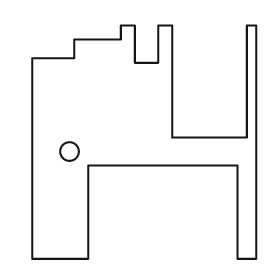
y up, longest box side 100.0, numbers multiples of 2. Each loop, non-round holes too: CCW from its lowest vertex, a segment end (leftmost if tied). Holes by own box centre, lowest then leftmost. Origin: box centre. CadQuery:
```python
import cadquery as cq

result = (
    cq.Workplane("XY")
    .moveTo(-48.0, -50.0)
    .lineTo(-24.0, -50.0)
    .lineTo(-24.0, -10.0)
    .lineTo(40.0, -10.0)
    .lineTo(40.0, -50.0)
    .lineTo(48.0, -50.0)
    .lineTo(48.0, 50.0)
    .lineTo(44.0, 50.0)
    .lineTo(44.0, 2.0)
    .lineTo(12.0, 2.0)
    .lineTo(12.0, 50.0)
    .lineTo(6.0, 50.0)
    .lineTo(6.0, 34.0)
    .lineTo(-4.0, 34.0)
    .lineTo(-4.0, 50.0)
    .lineTo(-10.0, 50.0)
    .lineTo(-10.0, 44.0)
    .lineTo(-30.0, 44.0)
    .lineTo(-30.0, 36.0)
    .lineTo(-48.0, 36.0)
    .close()
    .moveTo(-32.0, -4.0)
    .circle(4.0)
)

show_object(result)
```